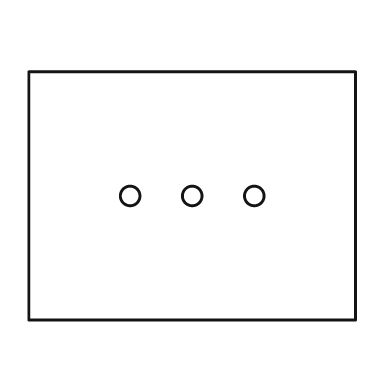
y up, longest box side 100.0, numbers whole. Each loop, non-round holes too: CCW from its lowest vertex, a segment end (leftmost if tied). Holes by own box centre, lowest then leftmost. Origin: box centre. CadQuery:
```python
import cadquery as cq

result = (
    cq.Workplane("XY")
    .moveTo(-50.0, -38.0)
    .lineTo(50.0, -38.0)
    .lineTo(50.0, 38.0)
    .lineTo(-50.0, 38.0)
    .close()
    .moveTo(-19.0, 0.0)
    .circle(3.0)
    .moveTo(0.0, 0.0)
    .circle(3.0)
    .moveTo(19.0, 0.0)
    .circle(3.0)
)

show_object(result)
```